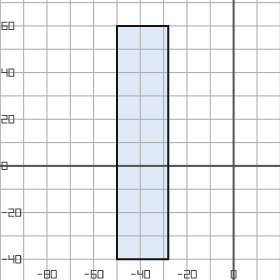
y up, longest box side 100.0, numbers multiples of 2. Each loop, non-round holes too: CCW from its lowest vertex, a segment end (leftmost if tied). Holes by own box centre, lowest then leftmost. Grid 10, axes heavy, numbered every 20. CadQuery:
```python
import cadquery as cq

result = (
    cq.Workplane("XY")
    .moveTo(-50.0, -40.0)
    .lineTo(-28.0, -40.0)
    .lineTo(-28.0, 60.0)
    .lineTo(-50.0, 60.0)
    .close()
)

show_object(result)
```